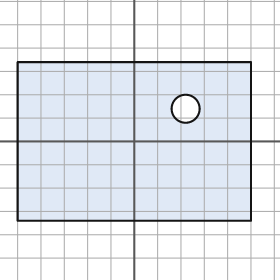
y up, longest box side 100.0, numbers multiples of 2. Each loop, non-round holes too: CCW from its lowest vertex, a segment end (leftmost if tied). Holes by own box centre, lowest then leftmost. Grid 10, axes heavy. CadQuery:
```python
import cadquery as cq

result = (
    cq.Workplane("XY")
    .moveTo(-50.0, -34.0)
    .lineTo(50.0, -34.0)
    .lineTo(50.0, 34.0)
    .lineTo(-50.0, 34.0)
    .close()
    .moveTo(22.0, 14.0)
    .circle(6.0)
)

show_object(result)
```